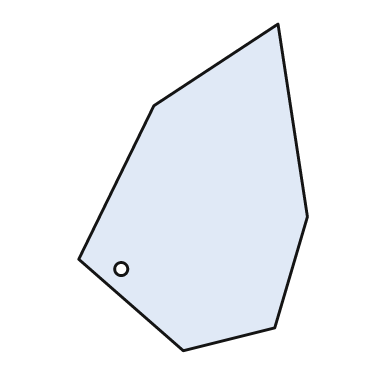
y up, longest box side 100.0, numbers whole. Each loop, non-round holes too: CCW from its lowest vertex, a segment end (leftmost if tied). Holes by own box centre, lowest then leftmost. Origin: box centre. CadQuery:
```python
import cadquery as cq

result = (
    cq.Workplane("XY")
    .moveTo(-3.0, -50.0)
    .lineTo(25.0, -43.0)
    .lineTo(35.0, -9.0)
    .lineTo(26.0, 50.0)
    .lineTo(-12.0, 25.0)
    .lineTo(-35.0, -22.0)
    .close()
    .moveTo(-22.0, -25.0)
    .circle(2.0)
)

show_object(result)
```